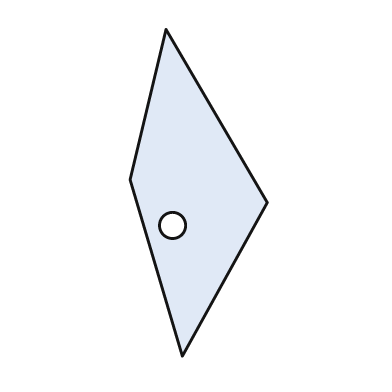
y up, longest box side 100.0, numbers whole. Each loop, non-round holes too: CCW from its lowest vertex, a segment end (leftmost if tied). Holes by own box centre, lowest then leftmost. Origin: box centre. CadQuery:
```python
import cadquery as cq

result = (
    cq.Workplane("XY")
    .moveTo(-5.0, -50.0)
    .lineTo(21.0, -3.0)
    .lineTo(-10.0, 50.0)
    .lineTo(-21.0, 4.0)
    .close()
    .moveTo(-8.0, -10.0)
    .circle(4.0)
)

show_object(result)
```